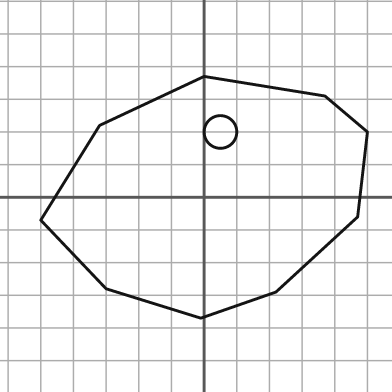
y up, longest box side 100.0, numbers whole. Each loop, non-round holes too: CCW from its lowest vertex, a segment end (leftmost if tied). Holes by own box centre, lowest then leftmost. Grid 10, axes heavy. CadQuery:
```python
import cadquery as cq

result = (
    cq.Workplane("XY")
    .moveTo(-1.0, -37.0)
    .lineTo(22.0, -29.0)
    .lineTo(47.0, -6.0)
    .lineTo(50.0, 20.0)
    .lineTo(37.0, 31.0)
    .lineTo(0.0, 37.0)
    .lineTo(-32.0, 22.0)
    .lineTo(-50.0, -7.0)
    .lineTo(-30.0, -28.0)
    .close()
    .moveTo(5.0, 20.0)
    .circle(5.0)
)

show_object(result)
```